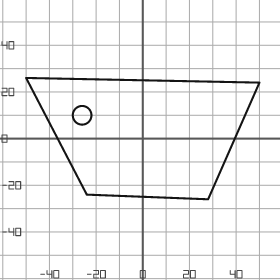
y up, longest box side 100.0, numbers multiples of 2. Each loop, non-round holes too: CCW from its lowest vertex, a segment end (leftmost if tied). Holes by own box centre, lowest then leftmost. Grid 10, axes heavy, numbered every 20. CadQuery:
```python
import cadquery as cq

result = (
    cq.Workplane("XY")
    .moveTo(28.0, -26.0)
    .lineTo(50.0, 24.0)
    .lineTo(-50.0, 26.0)
    .lineTo(-24.0, -24.0)
    .close()
    .moveTo(-26.0, 10.0)
    .circle(4.0)
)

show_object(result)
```